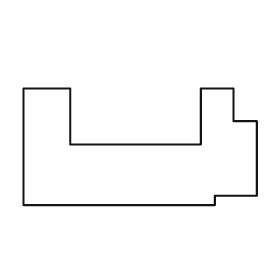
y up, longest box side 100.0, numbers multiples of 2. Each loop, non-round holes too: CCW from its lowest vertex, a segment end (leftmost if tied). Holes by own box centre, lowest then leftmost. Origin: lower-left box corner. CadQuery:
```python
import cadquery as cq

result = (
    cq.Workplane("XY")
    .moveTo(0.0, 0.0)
    .lineTo(82.0, 0.0)
    .lineTo(82.0, 4.0)
    .lineTo(100.0, 4.0)
    .lineTo(100.0, 36.0)
    .lineTo(90.0, 36.0)
    .lineTo(90.0, 50.0)
    .lineTo(76.0, 50.0)
    .lineTo(76.0, 26.0)
    .lineTo(20.0, 26.0)
    .lineTo(20.0, 50.0)
    .lineTo(0.0, 50.0)
    .close()
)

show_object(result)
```